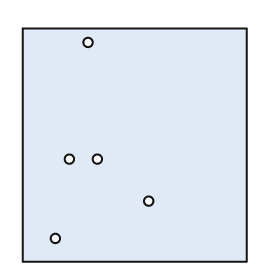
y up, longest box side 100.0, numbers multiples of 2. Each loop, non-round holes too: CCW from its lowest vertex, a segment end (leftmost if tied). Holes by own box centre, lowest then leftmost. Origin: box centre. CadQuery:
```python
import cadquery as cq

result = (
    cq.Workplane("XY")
    .moveTo(-48.0, -50.0)
    .lineTo(48.0, -50.0)
    .lineTo(48.0, 50.0)
    .lineTo(-48.0, 50.0)
    .close()
    .moveTo(-34.0, -40.0)
    .circle(2.0)
    .moveTo(6.0, -24.0)
    .circle(2.0)
    .moveTo(-28.0, -6.0)
    .circle(2.0)
    .moveTo(-16.0, -6.0)
    .circle(2.0)
    .moveTo(-20.0, 44.0)
    .circle(2.0)
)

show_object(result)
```